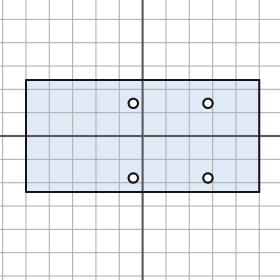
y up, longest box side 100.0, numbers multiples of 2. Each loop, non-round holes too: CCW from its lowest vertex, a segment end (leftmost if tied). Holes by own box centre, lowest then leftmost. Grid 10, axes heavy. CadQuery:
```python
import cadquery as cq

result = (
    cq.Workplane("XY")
    .moveTo(-50.0, -24.0)
    .lineTo(50.0, -24.0)
    .lineTo(50.0, 24.0)
    .lineTo(-50.0, 24.0)
    .close()
    .moveTo(-4.0, -18.0)
    .circle(2.0)
    .moveTo(28.0, -18.0)
    .circle(2.0)
    .moveTo(-4.0, 14.0)
    .circle(2.0)
    .moveTo(28.0, 14.0)
    .circle(2.0)
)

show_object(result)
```